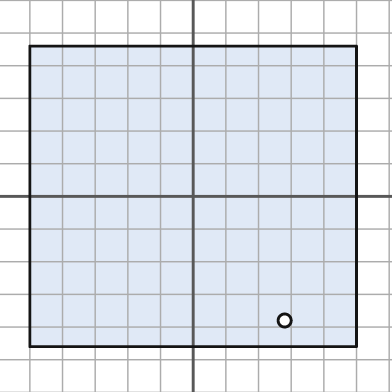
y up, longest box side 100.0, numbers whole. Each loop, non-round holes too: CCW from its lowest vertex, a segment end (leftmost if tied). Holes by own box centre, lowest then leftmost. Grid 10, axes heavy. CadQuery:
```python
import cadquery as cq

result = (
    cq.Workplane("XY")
    .moveTo(-50.0, -46.0)
    .lineTo(50.0, -46.0)
    .lineTo(50.0, 46.0)
    .lineTo(-50.0, 46.0)
    .close()
    .moveTo(28.0, -38.0)
    .circle(2.0)
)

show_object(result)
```